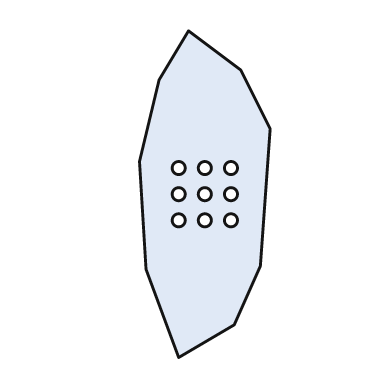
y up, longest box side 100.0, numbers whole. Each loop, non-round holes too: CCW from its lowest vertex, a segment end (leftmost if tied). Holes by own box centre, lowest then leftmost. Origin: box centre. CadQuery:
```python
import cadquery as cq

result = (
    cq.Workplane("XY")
    .moveTo(-8.0, -50.0)
    .lineTo(9.0, -40.0)
    .lineTo(17.0, -22.0)
    .lineTo(20.0, 20.0)
    .lineTo(11.0, 38.0)
    .lineTo(-5.0, 50.0)
    .lineTo(-14.0, 35.0)
    .lineTo(-20.0, 10.0)
    .lineTo(-18.0, -23.0)
    .close()
    .moveTo(-8.0, -8.0)
    .circle(2.0)
    .moveTo(0.0, -8.0)
    .circle(2.0)
    .moveTo(8.0, -8.0)
    .circle(2.0)
    .moveTo(-8.0, 0.0)
    .circle(2.0)
    .moveTo(0.0, 0.0)
    .circle(2.0)
    .moveTo(8.0, 0.0)
    .circle(2.0)
    .moveTo(-8.0, 8.0)
    .circle(2.0)
    .moveTo(0.0, 8.0)
    .circle(2.0)
    .moveTo(8.0, 8.0)
    .circle(2.0)
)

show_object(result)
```